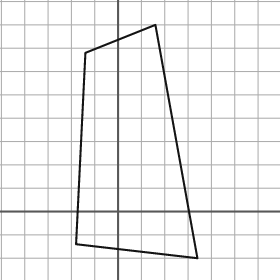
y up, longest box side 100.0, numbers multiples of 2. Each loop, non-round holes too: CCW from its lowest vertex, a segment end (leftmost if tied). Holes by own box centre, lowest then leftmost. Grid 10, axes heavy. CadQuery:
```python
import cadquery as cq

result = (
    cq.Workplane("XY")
    .moveTo(34.0, -20.0)
    .lineTo(16.0, 80.0)
    .lineTo(-14.0, 68.0)
    .lineTo(-18.0, -14.0)
    .close()
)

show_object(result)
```